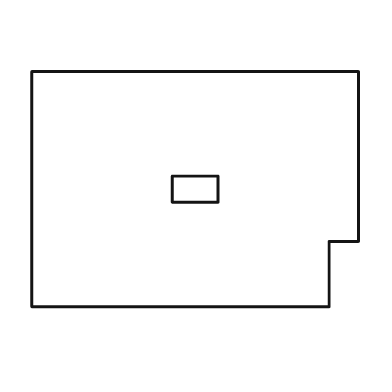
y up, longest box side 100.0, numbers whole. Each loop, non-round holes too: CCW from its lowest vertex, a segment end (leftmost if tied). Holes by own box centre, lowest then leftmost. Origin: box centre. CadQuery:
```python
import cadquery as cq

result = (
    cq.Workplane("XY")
    .moveTo(-50.0, -36.0)
    .lineTo(41.0, -36.0)
    .lineTo(41.0, -16.0)
    .lineTo(50.0, -16.0)
    .lineTo(50.0, 36.0)
    .lineTo(-50.0, 36.0)
    .close()
    .moveTo(-7.0, -4.0)
    .lineTo(7.0, -4.0)
    .lineTo(7.0, 4.0)
    .lineTo(-7.0, 4.0)
    .close()
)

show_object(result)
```